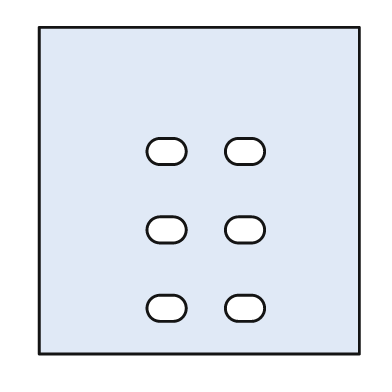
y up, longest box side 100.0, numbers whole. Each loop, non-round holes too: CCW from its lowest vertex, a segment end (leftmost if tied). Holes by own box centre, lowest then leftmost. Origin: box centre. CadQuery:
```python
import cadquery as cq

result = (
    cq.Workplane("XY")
    .moveTo(-49.0, -50.0)
    .lineTo(49.0, -50.0)
    .lineTo(49.0, 50.0)
    .lineTo(-49.0, 50.0)
    .close()
    .moveTo(-12.0, -40.0)
    .lineTo(-8.0, -40.0)
    .threePointArc((-4.0, -36.0), (-8.0, -32.0))
    .lineTo(-12.0, -32.0)
    .threePointArc((-16.0, -36.0), (-12.0, -40.0))
    .close()
    .moveTo(12.0, -40.0)
    .lineTo(16.0, -40.0)
    .threePointArc((20.0, -36.0), (16.0, -32.0))
    .lineTo(12.0, -32.0)
    .threePointArc((8.0, -36.0), (12.0, -40.0))
    .close()
    .moveTo(-12.0, -16.0)
    .lineTo(-8.0, -16.0)
    .threePointArc((-4.0, -12.0), (-8.0, -8.0))
    .lineTo(-12.0, -8.0)
    .threePointArc((-16.0, -12.0), (-12.0, -16.0))
    .close()
    .moveTo(12.0, -16.0)
    .lineTo(16.0, -16.0)
    .threePointArc((20.0, -12.0), (16.0, -8.0))
    .lineTo(12.0, -8.0)
    .threePointArc((8.0, -12.0), (12.0, -16.0))
    .close()
    .moveTo(-12.0, 8.0)
    .lineTo(-8.0, 8.0)
    .threePointArc((-4.0, 12.0), (-8.0, 16.0))
    .lineTo(-12.0, 16.0)
    .threePointArc((-16.0, 12.0), (-12.0, 8.0))
    .close()
    .moveTo(12.0, 8.0)
    .lineTo(16.0, 8.0)
    .threePointArc((20.0, 12.0), (16.0, 16.0))
    .lineTo(12.0, 16.0)
    .threePointArc((8.0, 12.0), (12.0, 8.0))
    .close()
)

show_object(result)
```